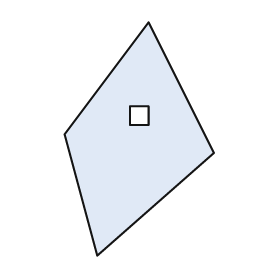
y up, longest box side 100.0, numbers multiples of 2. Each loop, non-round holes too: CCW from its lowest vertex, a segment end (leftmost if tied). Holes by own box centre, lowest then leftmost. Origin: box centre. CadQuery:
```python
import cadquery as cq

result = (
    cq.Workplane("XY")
    .moveTo(-18.0, -50.0)
    .lineTo(32.0, -6.0)
    .lineTo(4.0, 50.0)
    .lineTo(-32.0, 2.0)
    .close()
    .moveTo(-4.0, 6.0)
    .lineTo(4.0, 6.0)
    .lineTo(4.0, 14.0)
    .lineTo(-4.0, 14.0)
    .close()
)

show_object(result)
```